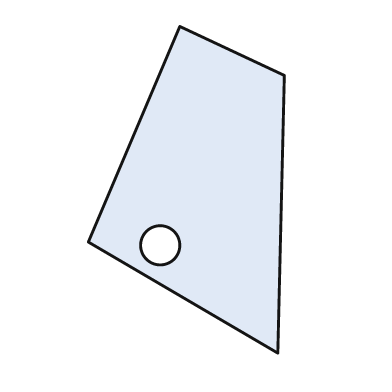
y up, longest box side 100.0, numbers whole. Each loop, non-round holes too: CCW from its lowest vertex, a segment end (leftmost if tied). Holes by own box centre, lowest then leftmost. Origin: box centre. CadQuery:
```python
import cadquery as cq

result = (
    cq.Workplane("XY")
    .moveTo(28.0, -50.0)
    .lineTo(30.0, 35.0)
    .lineTo(-2.0, 50.0)
    .lineTo(-30.0, -16.0)
    .close()
    .moveTo(-8.0, -17.0)
    .circle(6.0)
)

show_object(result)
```